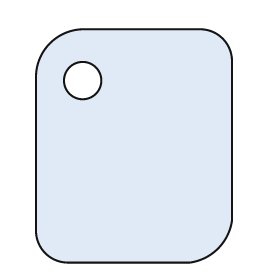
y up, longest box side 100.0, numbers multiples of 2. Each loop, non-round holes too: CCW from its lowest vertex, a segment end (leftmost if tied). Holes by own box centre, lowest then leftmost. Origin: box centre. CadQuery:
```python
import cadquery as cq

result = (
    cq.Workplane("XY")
    .moveTo(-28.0, -50.0)
    .lineTo(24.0, -50.0)
    .threePointArc((36.0, -44.0), (42.0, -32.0))
    .lineTo(42.0, 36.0)
    .threePointArc((38.0, 46.0), (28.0, 50.0))
    .lineTo(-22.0, 50.0)
    .threePointArc((-36.0, 44.0), (-42.0, 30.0))
    .lineTo(-42.0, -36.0)
    .threePointArc((-38.0, -46.0), (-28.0, -50.0))
    .close()
    .moveTo(-22.0, 28.0)
    .circle(8.0)
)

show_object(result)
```